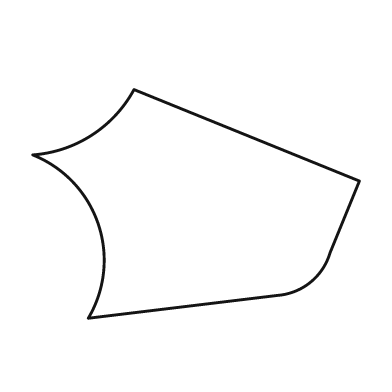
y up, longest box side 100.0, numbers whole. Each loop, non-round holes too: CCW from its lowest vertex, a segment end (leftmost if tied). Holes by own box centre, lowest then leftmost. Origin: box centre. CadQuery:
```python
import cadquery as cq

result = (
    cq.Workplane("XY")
    .moveTo(-33.0, -35.0)
    .lineTo(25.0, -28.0)
    .threePointArc((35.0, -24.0), (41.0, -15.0))
    .lineTo(50.0, 7.0)
    .lineTo(-19.0, 35.0)
    .threePointArc((-32.0, 21.0), (-50.0, 15.0))
    .threePointArc((-30.0, -6.0), (-33.0, -35.0))
    .close()
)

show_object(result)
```